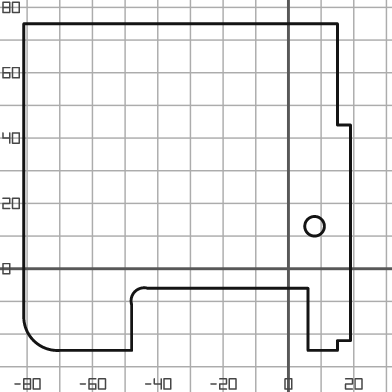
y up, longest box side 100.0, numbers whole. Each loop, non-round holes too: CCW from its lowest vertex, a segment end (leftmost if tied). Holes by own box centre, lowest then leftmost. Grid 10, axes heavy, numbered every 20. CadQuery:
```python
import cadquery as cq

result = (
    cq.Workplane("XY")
    .moveTo(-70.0, -25.0)
    .lineTo(-48.0, -25.0)
    .lineTo(-48.0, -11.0)
    .threePointArc((-47.0, -7.0), (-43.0, -6.0))
    .lineTo(6.0, -6.0)
    .lineTo(6.0, -25.0)
    .lineTo(15.0, -25.0)
    .lineTo(15.0, -22.0)
    .lineTo(19.0, -22.0)
    .lineTo(19.0, 44.0)
    .lineTo(15.0, 44.0)
    .lineTo(15.0, 75.0)
    .lineTo(-81.0, 75.0)
    .lineTo(-81.0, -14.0)
    .threePointArc((-78.0, -22.0), (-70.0, -25.0))
    .close()
    .moveTo(8.0, 13.0)
    .circle(3.0)
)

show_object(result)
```